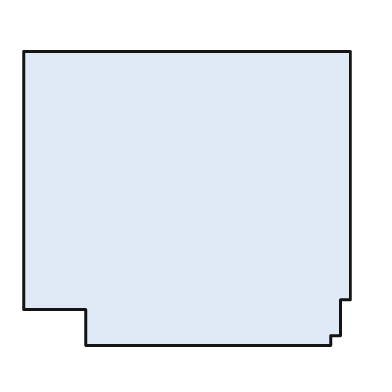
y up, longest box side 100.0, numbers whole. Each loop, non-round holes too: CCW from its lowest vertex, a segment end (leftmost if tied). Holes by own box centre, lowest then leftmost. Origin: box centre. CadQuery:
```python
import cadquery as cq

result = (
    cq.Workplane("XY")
    .moveTo(-31.0, -45.0)
    .lineTo(44.0, -45.0)
    .lineTo(44.0, -42.0)
    .lineTo(47.0, -42.0)
    .lineTo(47.0, -31.0)
    .lineTo(50.0, -31.0)
    .lineTo(50.0, 45.0)
    .lineTo(-50.0, 45.0)
    .lineTo(-50.0, -34.0)
    .lineTo(-31.0, -34.0)
    .close()
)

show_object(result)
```